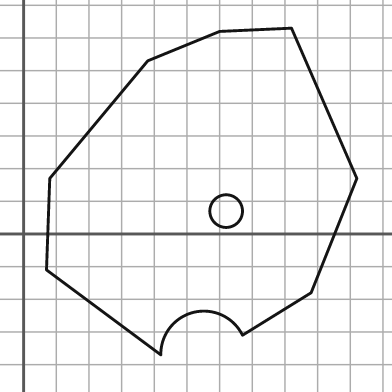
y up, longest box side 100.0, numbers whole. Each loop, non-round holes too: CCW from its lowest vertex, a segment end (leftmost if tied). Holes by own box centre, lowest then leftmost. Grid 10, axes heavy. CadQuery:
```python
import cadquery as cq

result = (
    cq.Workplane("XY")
    .moveTo(42.0, -37.0)
    .threePointArc((52.0, -24.0), (67.0, -31.0))
    .lineTo(88.0, -18.0)
    .lineTo(102.0, 17.0)
    .lineTo(82.0, 63.0)
    .lineTo(60.0, 62.0)
    .lineTo(38.0, 53.0)
    .lineTo(8.0, 17.0)
    .lineTo(7.0, -11.0)
    .close()
    .moveTo(62.0, 7.0)
    .circle(5.0)
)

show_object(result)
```